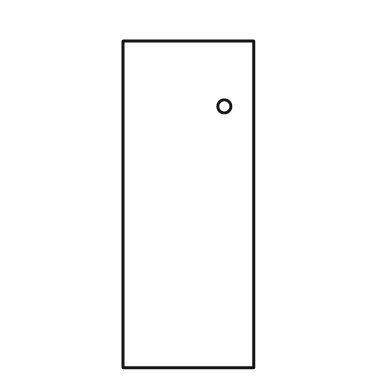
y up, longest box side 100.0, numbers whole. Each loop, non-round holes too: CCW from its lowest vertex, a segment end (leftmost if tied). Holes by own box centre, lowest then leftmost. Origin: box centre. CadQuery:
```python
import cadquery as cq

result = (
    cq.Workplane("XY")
    .moveTo(-20.0, -50.0)
    .lineTo(20.0, -50.0)
    .lineTo(20.0, 50.0)
    .lineTo(-20.0, 50.0)
    .close()
    .moveTo(11.0, 30.0)
    .circle(2.0)
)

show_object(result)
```